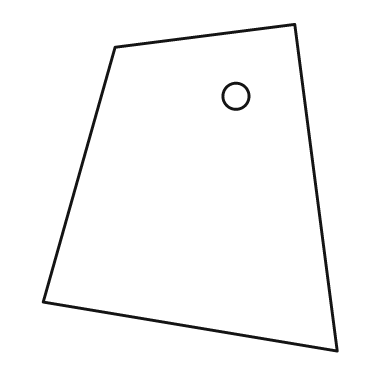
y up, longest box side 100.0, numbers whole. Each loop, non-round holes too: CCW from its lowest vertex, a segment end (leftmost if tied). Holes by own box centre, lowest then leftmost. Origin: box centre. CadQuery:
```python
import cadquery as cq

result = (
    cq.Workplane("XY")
    .moveTo(45.0, -50.0)
    .lineTo(32.0, 50.0)
    .lineTo(-23.0, 43.0)
    .lineTo(-45.0, -35.0)
    .close()
    .moveTo(14.0, 28.0)
    .circle(4.0)
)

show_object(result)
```